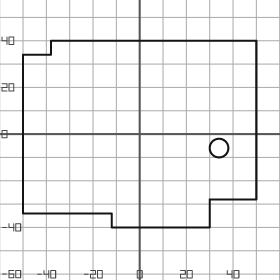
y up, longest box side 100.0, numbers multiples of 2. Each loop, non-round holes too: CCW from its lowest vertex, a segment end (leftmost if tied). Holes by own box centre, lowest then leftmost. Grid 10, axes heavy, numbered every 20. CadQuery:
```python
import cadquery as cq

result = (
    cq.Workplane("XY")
    .moveTo(-12.0, -40.0)
    .lineTo(30.0, -40.0)
    .lineTo(30.0, -28.0)
    .lineTo(50.0, -28.0)
    .lineTo(50.0, 40.0)
    .lineTo(-38.0, 40.0)
    .lineTo(-38.0, 34.0)
    .lineTo(-50.0, 34.0)
    .lineTo(-50.0, -34.0)
    .lineTo(-12.0, -34.0)
    .close()
    .moveTo(34.0, -6.0)
    .circle(4.0)
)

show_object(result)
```